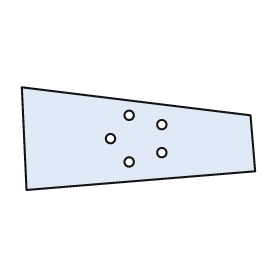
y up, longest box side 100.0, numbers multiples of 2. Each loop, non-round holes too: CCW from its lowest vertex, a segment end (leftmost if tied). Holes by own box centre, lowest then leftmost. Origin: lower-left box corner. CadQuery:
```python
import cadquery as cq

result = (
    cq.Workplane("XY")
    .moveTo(2.0, 0.0)
    .lineTo(100.0, 8.0)
    .lineTo(98.0, 32.0)
    .lineTo(0.0, 44.0)
    .close()
    .moveTo(46.0, 12.0)
    .circle(2.0)
    .moveTo(60.0, 16.0)
    .circle(2.0)
    .moveTo(38.0, 22.0)
    .circle(2.0)
    .moveTo(60.0, 28.0)
    .circle(2.0)
    .moveTo(46.0, 32.0)
    .circle(2.0)
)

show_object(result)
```